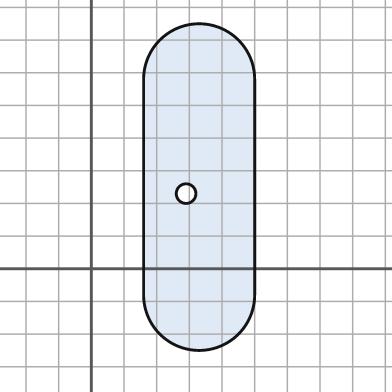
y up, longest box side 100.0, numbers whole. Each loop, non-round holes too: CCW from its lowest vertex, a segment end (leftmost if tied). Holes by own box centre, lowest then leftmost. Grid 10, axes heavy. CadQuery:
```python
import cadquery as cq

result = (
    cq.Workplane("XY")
    .moveTo(16.0, -8.0)
    .threePointArc((33.0, -25.0), (50.0, -8.0))
    .lineTo(50.0, 58.0)
    .threePointArc((33.0, 75.0), (16.0, 58.0))
    .close()
    .moveTo(29.0, 23.0)
    .circle(3.0)
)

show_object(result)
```